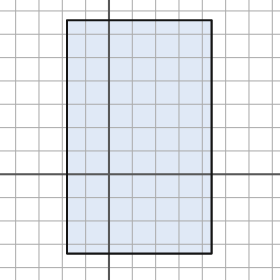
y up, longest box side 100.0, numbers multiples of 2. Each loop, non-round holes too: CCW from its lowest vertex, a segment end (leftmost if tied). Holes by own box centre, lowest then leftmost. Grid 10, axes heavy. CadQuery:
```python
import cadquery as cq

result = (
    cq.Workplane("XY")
    .moveTo(-18.0, -34.0)
    .lineTo(44.0, -34.0)
    .lineTo(44.0, 66.0)
    .lineTo(-18.0, 66.0)
    .close()
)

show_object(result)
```